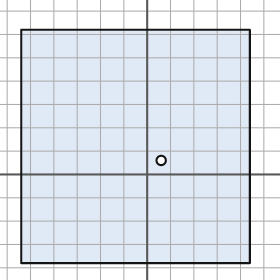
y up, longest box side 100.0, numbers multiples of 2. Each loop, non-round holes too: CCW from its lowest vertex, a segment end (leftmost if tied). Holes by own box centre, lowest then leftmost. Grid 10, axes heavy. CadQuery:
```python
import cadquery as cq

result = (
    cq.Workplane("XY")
    .moveTo(-54.0, -38.0)
    .lineTo(44.0, -38.0)
    .lineTo(44.0, 62.0)
    .lineTo(-54.0, 62.0)
    .close()
    .moveTo(6.0, 6.0)
    .circle(2.0)
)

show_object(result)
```